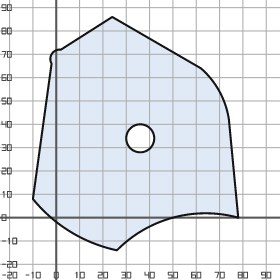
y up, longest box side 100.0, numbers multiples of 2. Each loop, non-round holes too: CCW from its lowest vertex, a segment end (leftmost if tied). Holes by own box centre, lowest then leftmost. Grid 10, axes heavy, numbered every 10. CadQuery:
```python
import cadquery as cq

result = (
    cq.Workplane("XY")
    .moveTo(26.0, -14.0)
    .threePointArc((50.0, 0.0), (78.0, 0.0))
    .lineTo(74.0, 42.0)
    .threePointArc((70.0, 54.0), (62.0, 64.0))
    .lineTo(24.0, 86.0)
    .lineTo(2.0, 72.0)
    .threePointArc((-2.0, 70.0), (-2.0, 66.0))
    .lineTo(-10.0, 8.0)
    .threePointArc((6.0, -6.0), (26.0, -14.0))
    .close()
    .moveTo(36.0, 34.0)
    .circle(6.0)
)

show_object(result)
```